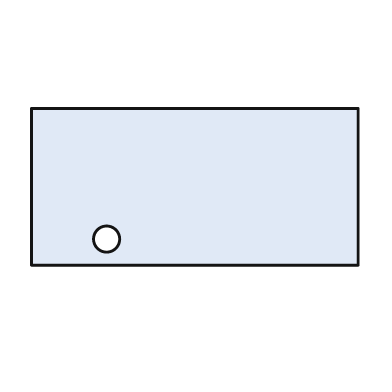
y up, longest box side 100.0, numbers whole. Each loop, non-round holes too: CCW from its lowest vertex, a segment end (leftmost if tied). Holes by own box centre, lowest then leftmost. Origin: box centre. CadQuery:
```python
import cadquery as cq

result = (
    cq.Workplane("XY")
    .moveTo(-50.0, -24.0)
    .lineTo(50.0, -24.0)
    .lineTo(50.0, 24.0)
    .lineTo(-50.0, 24.0)
    .close()
    .moveTo(-27.0, -16.0)
    .circle(4.0)
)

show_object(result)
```